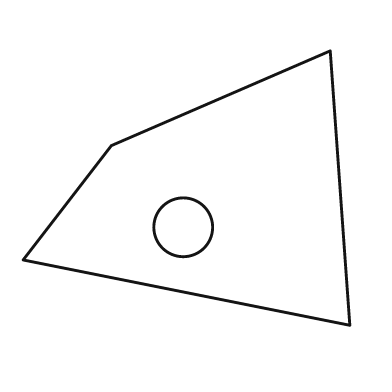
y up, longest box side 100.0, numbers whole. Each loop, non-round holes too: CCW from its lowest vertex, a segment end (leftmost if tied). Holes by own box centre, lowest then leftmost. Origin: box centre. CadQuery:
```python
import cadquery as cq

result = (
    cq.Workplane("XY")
    .moveTo(50.0, -42.0)
    .lineTo(44.0, 42.0)
    .lineTo(-23.0, 13.0)
    .lineTo(-50.0, -22.0)
    .close()
    .moveTo(-1.0, -12.0)
    .circle(9.0)
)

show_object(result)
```